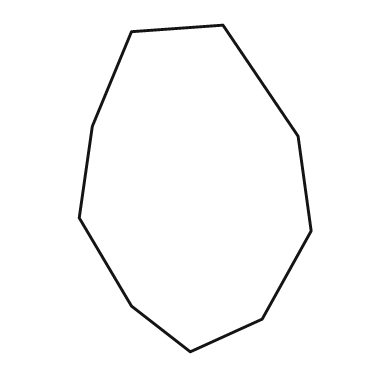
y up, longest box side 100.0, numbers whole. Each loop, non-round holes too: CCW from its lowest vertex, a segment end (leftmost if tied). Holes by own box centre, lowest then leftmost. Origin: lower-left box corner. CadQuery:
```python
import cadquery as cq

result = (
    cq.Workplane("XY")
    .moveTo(34.0, 0.0)
    .lineTo(56.0, 10.0)
    .lineTo(71.0, 37.0)
    .lineTo(67.0, 66.0)
    .lineTo(44.0, 100.0)
    .lineTo(16.0, 98.0)
    .lineTo(4.0, 69.0)
    .lineTo(0.0, 41.0)
    .lineTo(16.0, 14.0)
    .close()
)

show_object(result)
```